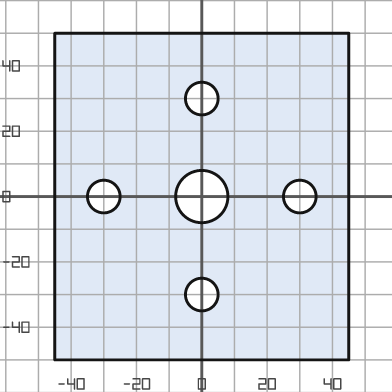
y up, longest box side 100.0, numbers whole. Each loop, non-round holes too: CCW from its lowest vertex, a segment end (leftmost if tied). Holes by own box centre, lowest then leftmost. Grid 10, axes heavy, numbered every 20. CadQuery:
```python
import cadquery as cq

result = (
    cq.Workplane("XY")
    .moveTo(-45.0, -50.0)
    .lineTo(45.0, -50.0)
    .lineTo(45.0, 50.0)
    .lineTo(-45.0, 50.0)
    .close()
    .moveTo(0.0, -30.0)
    .circle(5.0)
    .moveTo(-30.0, 0.0)
    .circle(5.0)
    .moveTo(0.0, 0.0)
    .circle(8.0)
    .moveTo(30.0, 0.0)
    .circle(5.0)
    .moveTo(0.0, 30.0)
    .circle(5.0)
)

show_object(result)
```